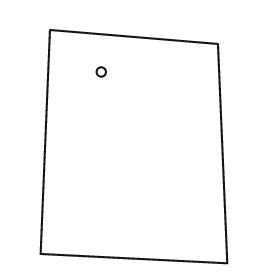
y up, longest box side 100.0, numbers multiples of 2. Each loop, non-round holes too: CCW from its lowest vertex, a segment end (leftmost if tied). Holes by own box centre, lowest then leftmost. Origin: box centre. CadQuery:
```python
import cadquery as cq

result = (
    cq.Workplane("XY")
    .moveTo(40.0, -50.0)
    .lineTo(36.0, 44.0)
    .lineTo(-36.0, 50.0)
    .lineTo(-40.0, -46.0)
    .close()
    .moveTo(-14.0, 32.0)
    .circle(2.0)
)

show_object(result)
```